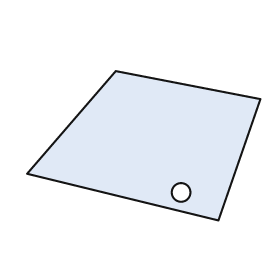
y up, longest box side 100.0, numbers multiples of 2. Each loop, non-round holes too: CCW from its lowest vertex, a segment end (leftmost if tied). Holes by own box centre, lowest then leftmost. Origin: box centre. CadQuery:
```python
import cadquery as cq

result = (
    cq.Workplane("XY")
    .moveTo(32.0, -32.0)
    .lineTo(50.0, 20.0)
    .lineTo(-12.0, 32.0)
    .lineTo(-50.0, -12.0)
    .close()
    .moveTo(16.0, -20.0)
    .circle(4.0)
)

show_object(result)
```